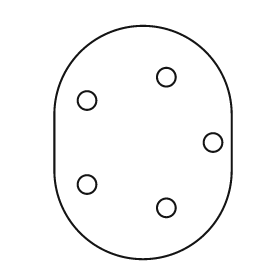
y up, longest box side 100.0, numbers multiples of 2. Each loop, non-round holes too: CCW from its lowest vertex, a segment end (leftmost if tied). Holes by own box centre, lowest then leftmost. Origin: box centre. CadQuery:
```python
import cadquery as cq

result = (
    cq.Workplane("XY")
    .moveTo(-38.0, -12.0)
    .threePointArc((0.0, -50.0), (38.0, -12.0))
    .lineTo(38.0, 12.0)
    .threePointArc((0.0, 50.0), (-38.0, 12.0))
    .close()
    .moveTo(10.0, -28.0)
    .circle(4.0)
    .moveTo(-24.0, -18.0)
    .circle(4.0)
    .moveTo(30.0, 0.0)
    .circle(4.0)
    .moveTo(-24.0, 18.0)
    .circle(4.0)
    .moveTo(10.0, 28.0)
    .circle(4.0)
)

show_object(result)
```